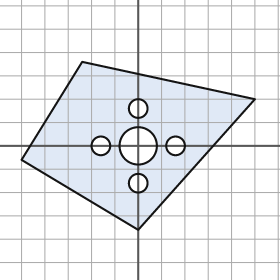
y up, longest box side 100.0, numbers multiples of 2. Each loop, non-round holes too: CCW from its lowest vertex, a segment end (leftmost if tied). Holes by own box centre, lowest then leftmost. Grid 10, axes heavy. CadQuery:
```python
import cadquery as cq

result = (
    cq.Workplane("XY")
    .moveTo(0.0, -36.0)
    .lineTo(50.0, 20.0)
    .lineTo(-24.0, 36.0)
    .lineTo(-50.0, -6.0)
    .close()
    .moveTo(0.0, -16.0)
    .circle(4.0)
    .moveTo(-16.0, 0.0)
    .circle(4.0)
    .moveTo(0.0, 0.0)
    .circle(8.0)
    .moveTo(16.0, 0.0)
    .circle(4.0)
    .moveTo(0.0, 16.0)
    .circle(4.0)
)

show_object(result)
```